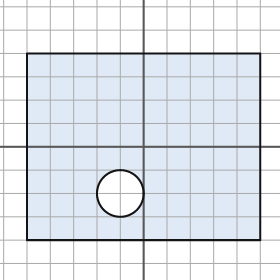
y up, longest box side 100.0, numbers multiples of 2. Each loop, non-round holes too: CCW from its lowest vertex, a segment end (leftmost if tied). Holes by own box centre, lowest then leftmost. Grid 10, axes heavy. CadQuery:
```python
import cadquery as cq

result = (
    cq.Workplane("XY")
    .moveTo(-50.0, -40.0)
    .lineTo(50.0, -40.0)
    .lineTo(50.0, 40.0)
    .lineTo(-50.0, 40.0)
    .close()
    .moveTo(-10.0, -20.0)
    .circle(10.0)
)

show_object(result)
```